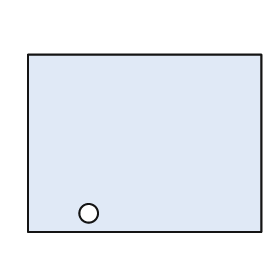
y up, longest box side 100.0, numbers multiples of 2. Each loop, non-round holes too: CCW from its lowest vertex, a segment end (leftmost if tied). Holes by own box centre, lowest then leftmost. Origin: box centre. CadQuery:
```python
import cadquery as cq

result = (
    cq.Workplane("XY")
    .moveTo(-50.0, -38.0)
    .lineTo(50.0, -38.0)
    .lineTo(50.0, 38.0)
    .lineTo(-50.0, 38.0)
    .close()
    .moveTo(-24.0, -30.0)
    .circle(4.0)
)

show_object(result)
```